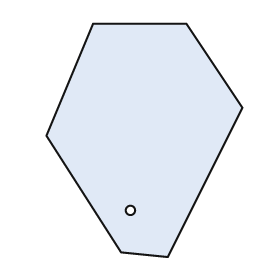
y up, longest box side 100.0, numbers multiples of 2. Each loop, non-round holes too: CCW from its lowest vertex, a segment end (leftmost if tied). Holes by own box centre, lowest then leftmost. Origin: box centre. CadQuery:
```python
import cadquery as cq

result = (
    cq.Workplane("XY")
    .moveTo(10.0, -50.0)
    .lineTo(42.0, 14.0)
    .lineTo(18.0, 50.0)
    .lineTo(-22.0, 50.0)
    .lineTo(-42.0, 2.0)
    .lineTo(-10.0, -48.0)
    .close()
    .moveTo(-6.0, -30.0)
    .circle(2.0)
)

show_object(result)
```